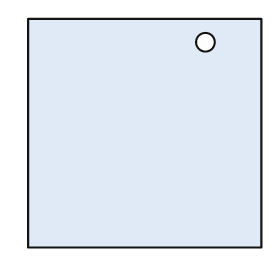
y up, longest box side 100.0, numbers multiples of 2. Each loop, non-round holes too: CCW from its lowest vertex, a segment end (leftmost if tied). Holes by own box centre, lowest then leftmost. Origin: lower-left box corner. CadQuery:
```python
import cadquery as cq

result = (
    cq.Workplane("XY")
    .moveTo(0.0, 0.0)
    .lineTo(100.0, 0.0)
    .lineTo(100.0, 98.0)
    .lineTo(0.0, 98.0)
    .close()
    .moveTo(76.0, 88.0)
    .circle(4.0)
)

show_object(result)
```